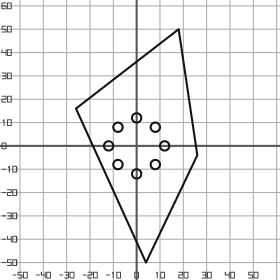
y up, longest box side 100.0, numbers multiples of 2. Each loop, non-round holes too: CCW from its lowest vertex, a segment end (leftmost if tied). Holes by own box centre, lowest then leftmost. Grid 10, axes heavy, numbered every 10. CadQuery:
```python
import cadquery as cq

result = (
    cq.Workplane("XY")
    .moveTo(4.0, -50.0)
    .lineTo(26.0, -4.0)
    .lineTo(18.0, 50.0)
    .lineTo(-26.0, 16.0)
    .close()
    .moveTo(0.0, -12.0)
    .circle(2.0)
    .moveTo(-8.0, -8.0)
    .circle(2.0)
    .moveTo(8.0, -8.0)
    .circle(2.0)
    .moveTo(-12.0, 0.0)
    .circle(2.0)
    .moveTo(12.0, 0.0)
    .circle(2.0)
    .moveTo(-8.0, 8.0)
    .circle(2.0)
    .moveTo(8.0, 8.0)
    .circle(2.0)
    .moveTo(0.0, 12.0)
    .circle(2.0)
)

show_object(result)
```